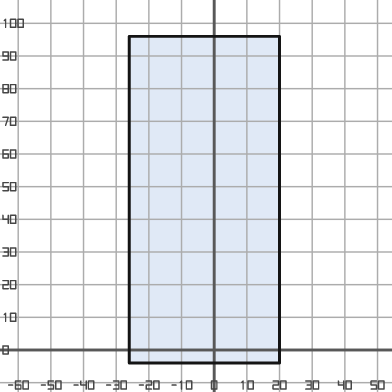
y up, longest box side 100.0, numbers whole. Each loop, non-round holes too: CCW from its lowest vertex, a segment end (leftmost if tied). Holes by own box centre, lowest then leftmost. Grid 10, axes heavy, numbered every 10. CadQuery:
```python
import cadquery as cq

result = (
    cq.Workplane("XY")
    .moveTo(-26.0, -4.0)
    .lineTo(20.0, -4.0)
    .lineTo(20.0, 96.0)
    .lineTo(-26.0, 96.0)
    .close()
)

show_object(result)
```